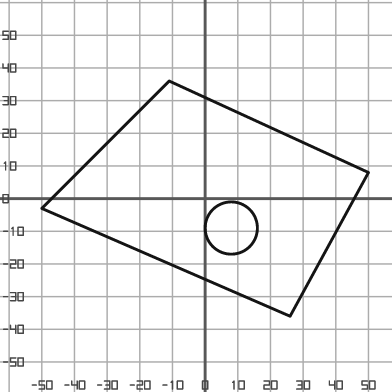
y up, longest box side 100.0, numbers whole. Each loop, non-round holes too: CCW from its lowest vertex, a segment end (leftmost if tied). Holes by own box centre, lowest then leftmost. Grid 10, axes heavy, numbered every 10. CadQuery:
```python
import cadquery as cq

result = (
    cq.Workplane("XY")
    .moveTo(26.0, -36.0)
    .lineTo(50.0, 8.0)
    .lineTo(-11.0, 36.0)
    .lineTo(-50.0, -3.0)
    .close()
    .moveTo(8.0, -9.0)
    .circle(8.0)
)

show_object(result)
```